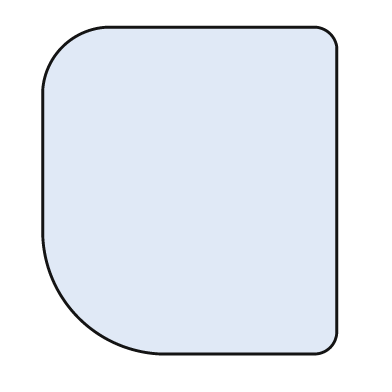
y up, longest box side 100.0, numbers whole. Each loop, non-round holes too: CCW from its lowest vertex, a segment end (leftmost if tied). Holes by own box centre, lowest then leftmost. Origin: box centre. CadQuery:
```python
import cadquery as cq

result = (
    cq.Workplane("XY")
    .moveTo(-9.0, -50.0)
    .lineTo(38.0, -50.0)
    .threePointArc((43.0, -48.0), (45.0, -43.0))
    .lineTo(45.0, 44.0)
    .threePointArc((43.0, 48.0), (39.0, 50.0))
    .lineTo(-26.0, 50.0)
    .threePointArc((-39.0, 44.0), (-45.0, 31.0))
    .lineTo(-45.0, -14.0)
    .threePointArc((-34.0, -39.0), (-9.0, -50.0))
    .close()
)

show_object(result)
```